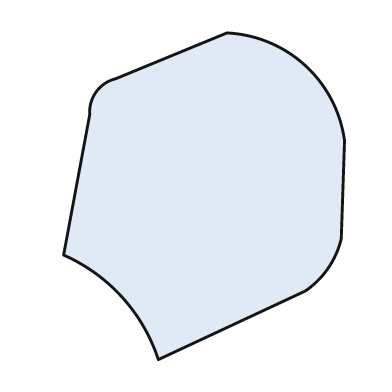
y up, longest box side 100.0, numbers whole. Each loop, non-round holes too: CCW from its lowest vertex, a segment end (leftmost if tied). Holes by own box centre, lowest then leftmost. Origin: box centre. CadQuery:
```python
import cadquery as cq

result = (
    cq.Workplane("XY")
    .moveTo(-14.0, -50.0)
    .lineTo(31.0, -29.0)
    .threePointArc((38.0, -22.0), (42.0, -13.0))
    .lineTo(43.0, 17.0)
    .threePointArc((31.0, 40.0), (7.0, 50.0))
    .lineTo(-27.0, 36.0)
    .threePointArc((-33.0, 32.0), (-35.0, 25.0))
    .lineTo(-43.0, -18.0)
    .threePointArc((-25.0, -31.0), (-14.0, -50.0))
    .close()
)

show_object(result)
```